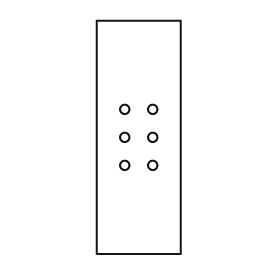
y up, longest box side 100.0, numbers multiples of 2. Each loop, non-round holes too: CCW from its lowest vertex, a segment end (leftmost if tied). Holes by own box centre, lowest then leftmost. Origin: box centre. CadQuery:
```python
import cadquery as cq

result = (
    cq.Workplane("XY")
    .moveTo(-18.0, -50.0)
    .lineTo(18.0, -50.0)
    .lineTo(18.0, 50.0)
    .lineTo(-18.0, 50.0)
    .close()
    .moveTo(-6.0, -12.0)
    .circle(2.0)
    .moveTo(6.0, -12.0)
    .circle(2.0)
    .moveTo(-6.0, 0.0)
    .circle(2.0)
    .moveTo(6.0, 0.0)
    .circle(2.0)
    .moveTo(-6.0, 12.0)
    .circle(2.0)
    .moveTo(6.0, 12.0)
    .circle(2.0)
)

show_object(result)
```